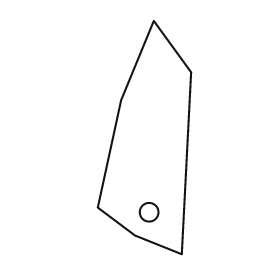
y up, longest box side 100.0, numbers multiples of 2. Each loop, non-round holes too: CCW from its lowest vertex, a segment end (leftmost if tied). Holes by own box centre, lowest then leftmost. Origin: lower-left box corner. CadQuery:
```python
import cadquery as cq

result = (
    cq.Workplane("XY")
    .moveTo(36.0, 0.0)
    .lineTo(40.0, 78.0)
    .lineTo(24.0, 100.0)
    .lineTo(10.0, 66.0)
    .lineTo(0.0, 20.0)
    .lineTo(16.0, 8.0)
    .close()
    .moveTo(22.0, 18.0)
    .circle(4.0)
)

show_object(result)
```